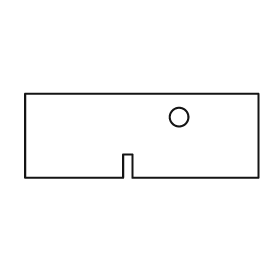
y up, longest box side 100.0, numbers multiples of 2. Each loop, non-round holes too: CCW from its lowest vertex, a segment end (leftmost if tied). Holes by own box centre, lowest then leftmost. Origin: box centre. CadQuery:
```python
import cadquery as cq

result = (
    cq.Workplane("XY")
    .moveTo(-50.0, -18.0)
    .lineTo(-8.0, -18.0)
    .lineTo(-8.0, -8.0)
    .lineTo(-4.0, -8.0)
    .lineTo(-4.0, -18.0)
    .lineTo(50.0, -18.0)
    .lineTo(50.0, 18.0)
    .lineTo(-50.0, 18.0)
    .close()
    .moveTo(16.0, 8.0)
    .circle(4.0)
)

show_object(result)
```